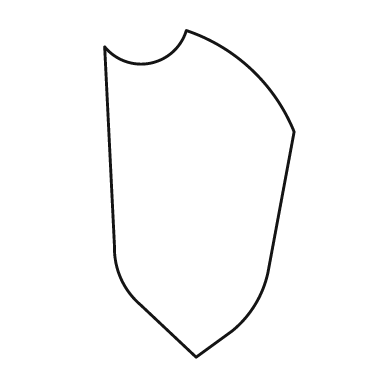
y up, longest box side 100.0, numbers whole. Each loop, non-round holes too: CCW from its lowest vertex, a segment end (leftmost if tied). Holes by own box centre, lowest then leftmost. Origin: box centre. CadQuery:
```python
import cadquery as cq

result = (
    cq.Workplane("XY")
    .moveTo(-1.0, -50.0)
    .lineTo(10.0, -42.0)
    .threePointArc((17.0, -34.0), (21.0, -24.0))
    .lineTo(29.0, 19.0)
    .threePointArc((16.0, 38.0), (-4.0, 50.0))
    .threePointArc((-15.0, 40.0), (-29.0, 45.0))
    .lineTo(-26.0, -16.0)
    .threePointArc((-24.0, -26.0), (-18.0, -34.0))
    .close()
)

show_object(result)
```